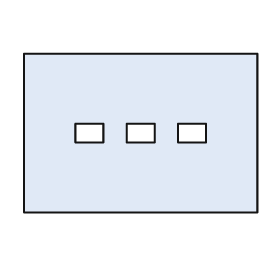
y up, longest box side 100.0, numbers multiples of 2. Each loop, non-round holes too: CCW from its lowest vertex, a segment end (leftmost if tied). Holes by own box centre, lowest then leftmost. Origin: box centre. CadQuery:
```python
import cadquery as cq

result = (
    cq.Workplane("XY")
    .moveTo(-50.0, -34.0)
    .lineTo(50.0, -34.0)
    .lineTo(50.0, 34.0)
    .lineTo(-50.0, 34.0)
    .close()
    .moveTo(-28.0, -4.0)
    .lineTo(-16.0, -4.0)
    .lineTo(-16.0, 4.0)
    .lineTo(-28.0, 4.0)
    .close()
    .moveTo(-6.0, -4.0)
    .lineTo(6.0, -4.0)
    .lineTo(6.0, 4.0)
    .lineTo(-6.0, 4.0)
    .close()
    .moveTo(16.0, -4.0)
    .lineTo(28.0, -4.0)
    .lineTo(28.0, 4.0)
    .lineTo(16.0, 4.0)
    .close()
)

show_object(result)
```